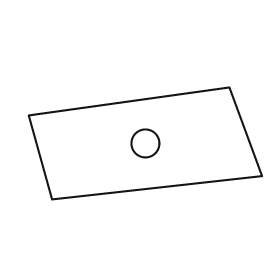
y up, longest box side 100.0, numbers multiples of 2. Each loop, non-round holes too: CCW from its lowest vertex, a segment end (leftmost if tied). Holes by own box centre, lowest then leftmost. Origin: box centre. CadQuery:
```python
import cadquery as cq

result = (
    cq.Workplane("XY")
    .moveTo(-40.0, -24.0)
    .lineTo(50.0, -14.0)
    .lineTo(36.0, 24.0)
    .lineTo(-50.0, 12.0)
    .close()
    .moveTo(0.0, 0.0)
    .circle(6.0)
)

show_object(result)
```